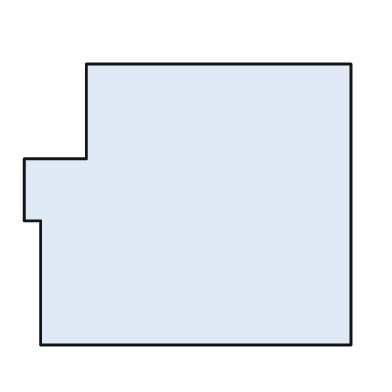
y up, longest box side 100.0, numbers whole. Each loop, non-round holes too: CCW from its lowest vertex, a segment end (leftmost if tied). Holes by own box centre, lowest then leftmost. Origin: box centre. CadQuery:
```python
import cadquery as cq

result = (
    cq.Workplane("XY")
    .moveTo(-45.0, -43.0)
    .lineTo(50.0, -43.0)
    .lineTo(50.0, 43.0)
    .lineTo(-31.0, 43.0)
    .lineTo(-31.0, 14.0)
    .lineTo(-50.0, 14.0)
    .lineTo(-50.0, -5.0)
    .lineTo(-45.0, -5.0)
    .close()
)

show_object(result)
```